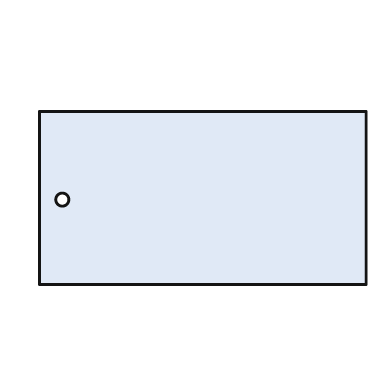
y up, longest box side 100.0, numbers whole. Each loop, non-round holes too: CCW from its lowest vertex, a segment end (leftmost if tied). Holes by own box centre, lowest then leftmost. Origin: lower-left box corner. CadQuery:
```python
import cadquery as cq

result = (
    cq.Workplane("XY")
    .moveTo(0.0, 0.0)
    .lineTo(100.0, 0.0)
    .lineTo(100.0, 53.0)
    .lineTo(0.0, 53.0)
    .close()
    .moveTo(7.0, 26.0)
    .circle(2.0)
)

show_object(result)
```